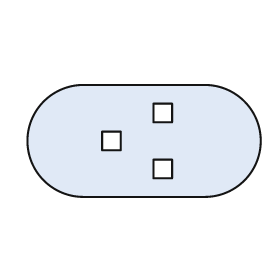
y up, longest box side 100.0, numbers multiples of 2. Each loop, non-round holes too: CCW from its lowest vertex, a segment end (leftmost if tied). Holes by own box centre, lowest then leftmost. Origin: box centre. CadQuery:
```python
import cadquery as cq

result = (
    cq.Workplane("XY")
    .moveTo(-26.0, -24.0)
    .lineTo(26.0, -24.0)
    .threePointArc((50.0, 0.0), (26.0, 24.0))
    .lineTo(-26.0, 24.0)
    .threePointArc((-50.0, 0.0), (-26.0, -24.0))
    .close()
    .moveTo(4.0, -16.0)
    .lineTo(12.0, -16.0)
    .lineTo(12.0, -8.0)
    .lineTo(4.0, -8.0)
    .close()
    .moveTo(-18.0, -4.0)
    .lineTo(-10.0, -4.0)
    .lineTo(-10.0, 4.0)
    .lineTo(-18.0, 4.0)
    .close()
    .moveTo(4.0, 8.0)
    .lineTo(12.0, 8.0)
    .lineTo(12.0, 16.0)
    .lineTo(4.0, 16.0)
    .close()
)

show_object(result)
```